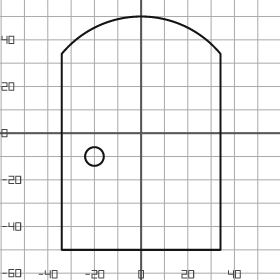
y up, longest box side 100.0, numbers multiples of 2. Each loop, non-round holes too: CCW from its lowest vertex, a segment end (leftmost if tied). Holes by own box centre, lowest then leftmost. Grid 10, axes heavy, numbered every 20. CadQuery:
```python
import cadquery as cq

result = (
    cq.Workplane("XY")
    .moveTo(-34.0, -50.0)
    .lineTo(34.0, -50.0)
    .lineTo(34.0, 34.0)
    .threePointArc((0.0, 50.0), (-34.0, 34.0))
    .close()
    .moveTo(-20.0, -10.0)
    .circle(4.0)
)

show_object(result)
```